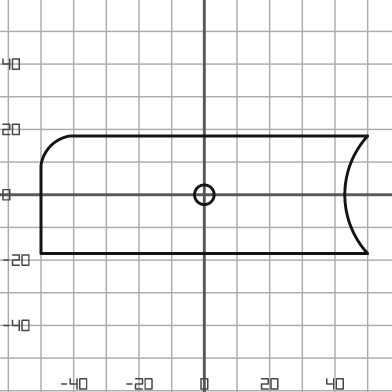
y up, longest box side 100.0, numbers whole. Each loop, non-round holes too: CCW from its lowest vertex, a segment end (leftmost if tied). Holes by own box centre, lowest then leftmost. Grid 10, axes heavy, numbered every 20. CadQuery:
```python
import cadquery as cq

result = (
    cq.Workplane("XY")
    .moveTo(-50.0, -18.0)
    .lineTo(50.0, -18.0)
    .threePointArc((43.0, 0.0), (50.0, 18.0))
    .lineTo(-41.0, 18.0)
    .threePointArc((-47.0, 15.0), (-50.0, 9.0))
    .close()
    .moveTo(0.0, 0.0)
    .circle(3.0)
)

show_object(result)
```